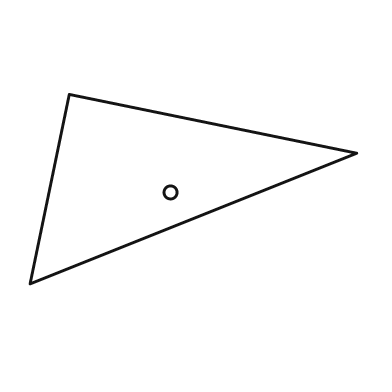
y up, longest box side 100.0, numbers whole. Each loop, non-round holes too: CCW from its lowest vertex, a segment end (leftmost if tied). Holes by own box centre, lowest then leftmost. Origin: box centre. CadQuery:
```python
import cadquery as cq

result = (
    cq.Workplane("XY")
    .moveTo(-50.0, -29.0)
    .lineTo(50.0, 11.0)
    .lineTo(-38.0, 29.0)
    .close()
    .moveTo(-7.0, -1.0)
    .circle(2.0)
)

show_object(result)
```